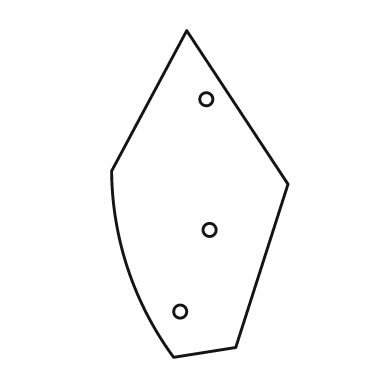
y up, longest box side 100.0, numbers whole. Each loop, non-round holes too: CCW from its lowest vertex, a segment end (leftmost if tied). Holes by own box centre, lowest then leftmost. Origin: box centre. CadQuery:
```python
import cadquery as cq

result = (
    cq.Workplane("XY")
    .moveTo(-8.0, -50.0)
    .lineTo(11.0, -47.0)
    .lineTo(27.0, 3.0)
    .lineTo(-4.0, 50.0)
    .lineTo(-27.0, 7.0)
    .threePointArc((-22.0, -23.0), (-8.0, -50.0))
    .close()
    .moveTo(-6.0, -36.0)
    .circle(2.0)
    .moveTo(3.0, -11.0)
    .circle(2.0)
    .moveTo(2.0, 29.0)
    .circle(2.0)
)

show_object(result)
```